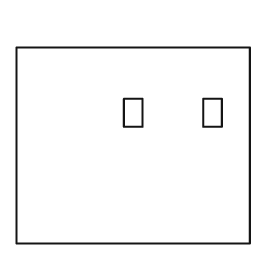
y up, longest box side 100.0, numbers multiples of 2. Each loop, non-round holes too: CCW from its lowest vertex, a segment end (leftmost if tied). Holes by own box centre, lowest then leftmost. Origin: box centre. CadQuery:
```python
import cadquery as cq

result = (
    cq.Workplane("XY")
    .moveTo(-50.0, -42.0)
    .lineTo(50.0, -42.0)
    .lineTo(50.0, 42.0)
    .lineTo(-50.0, 42.0)
    .close()
    .moveTo(-4.0, 8.0)
    .lineTo(4.0, 8.0)
    .lineTo(4.0, 20.0)
    .lineTo(-4.0, 20.0)
    .close()
    .moveTo(30.0, 8.0)
    .lineTo(38.0, 8.0)
    .lineTo(38.0, 20.0)
    .lineTo(30.0, 20.0)
    .close()
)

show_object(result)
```